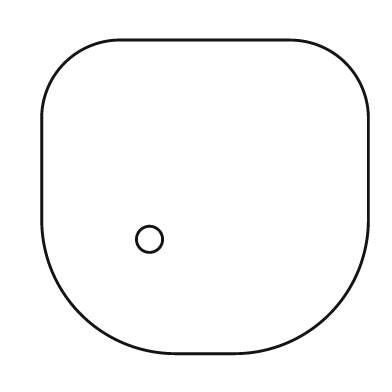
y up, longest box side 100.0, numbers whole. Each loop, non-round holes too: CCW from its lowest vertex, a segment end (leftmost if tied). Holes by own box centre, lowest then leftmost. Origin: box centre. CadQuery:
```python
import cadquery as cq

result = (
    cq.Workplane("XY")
    .moveTo(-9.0, -48.0)
    .lineTo(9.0, -48.0)
    .threePointArc((38.0, -36.0), (50.0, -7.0))
    .lineTo(50.0, 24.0)
    .threePointArc((43.0, 41.0), (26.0, 48.0))
    .lineTo(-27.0, 48.0)
    .threePointArc((-43.0, 41.0), (-50.0, 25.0))
    .lineTo(-50.0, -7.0)
    .threePointArc((-38.0, -36.0), (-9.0, -48.0))
    .close()
    .moveTo(-17.0, -13.0)
    .circle(4.0)
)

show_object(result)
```